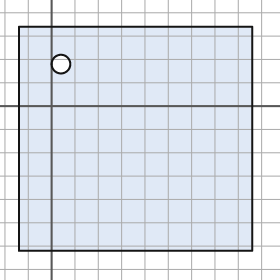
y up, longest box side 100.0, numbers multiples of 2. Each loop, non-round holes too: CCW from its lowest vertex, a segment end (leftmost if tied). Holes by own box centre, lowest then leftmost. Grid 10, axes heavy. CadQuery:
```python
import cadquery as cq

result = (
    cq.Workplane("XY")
    .moveTo(-14.0, -62.0)
    .lineTo(86.0, -62.0)
    .lineTo(86.0, 34.0)
    .lineTo(-14.0, 34.0)
    .close()
    .moveTo(4.0, 18.0)
    .circle(4.0)
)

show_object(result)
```